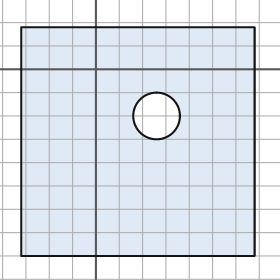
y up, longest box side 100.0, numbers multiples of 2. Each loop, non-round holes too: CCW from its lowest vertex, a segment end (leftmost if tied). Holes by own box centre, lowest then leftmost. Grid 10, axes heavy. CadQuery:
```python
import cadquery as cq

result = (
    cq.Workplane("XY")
    .moveTo(-32.0, -80.0)
    .lineTo(68.0, -80.0)
    .lineTo(68.0, 18.0)
    .lineTo(-32.0, 18.0)
    .close()
    .moveTo(26.0, -20.0)
    .circle(10.0)
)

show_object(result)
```